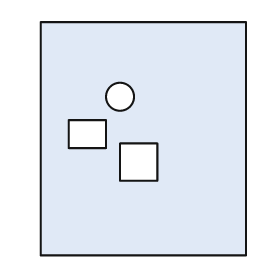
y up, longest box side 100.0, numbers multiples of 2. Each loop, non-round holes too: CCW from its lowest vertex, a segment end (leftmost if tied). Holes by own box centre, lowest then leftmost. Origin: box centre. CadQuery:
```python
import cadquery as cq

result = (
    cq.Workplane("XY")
    .moveTo(-44.0, -50.0)
    .lineTo(44.0, -50.0)
    .lineTo(44.0, 50.0)
    .lineTo(-44.0, 50.0)
    .close()
    .moveTo(-10.0, -18.0)
    .lineTo(6.0, -18.0)
    .lineTo(6.0, -2.0)
    .lineTo(-10.0, -2.0)
    .close()
    .moveTo(-32.0, -4.0)
    .lineTo(-16.0, -4.0)
    .lineTo(-16.0, 8.0)
    .lineTo(-32.0, 8.0)
    .close()
    .moveTo(-10.0, 18.0)
    .circle(6.0)
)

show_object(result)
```